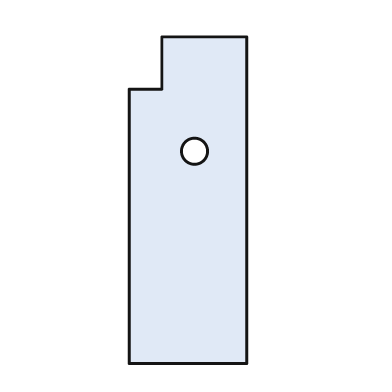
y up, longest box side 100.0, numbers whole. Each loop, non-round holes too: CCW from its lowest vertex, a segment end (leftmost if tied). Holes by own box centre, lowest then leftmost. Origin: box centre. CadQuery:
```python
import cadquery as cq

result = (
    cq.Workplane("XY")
    .moveTo(-18.0, -50.0)
    .lineTo(18.0, -50.0)
    .lineTo(18.0, 50.0)
    .lineTo(-8.0, 50.0)
    .lineTo(-8.0, 34.0)
    .lineTo(-18.0, 34.0)
    .close()
    .moveTo(2.0, 15.0)
    .circle(4.0)
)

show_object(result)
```